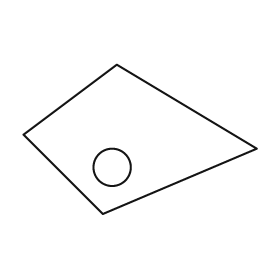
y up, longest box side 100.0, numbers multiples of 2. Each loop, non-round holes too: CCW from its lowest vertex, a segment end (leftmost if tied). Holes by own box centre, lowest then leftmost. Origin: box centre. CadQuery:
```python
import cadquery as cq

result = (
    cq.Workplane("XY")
    .moveTo(-16.0, -32.0)
    .lineTo(50.0, -4.0)
    .lineTo(-10.0, 32.0)
    .lineTo(-50.0, 2.0)
    .close()
    .moveTo(-12.0, -12.0)
    .circle(8.0)
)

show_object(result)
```